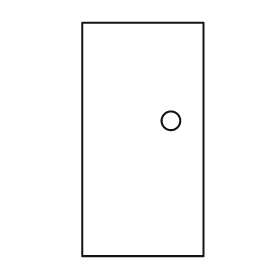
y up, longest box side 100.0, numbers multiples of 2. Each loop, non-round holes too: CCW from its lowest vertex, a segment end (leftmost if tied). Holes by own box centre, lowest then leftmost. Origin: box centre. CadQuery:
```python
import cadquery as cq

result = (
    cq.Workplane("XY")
    .moveTo(-26.0, -50.0)
    .lineTo(26.0, -50.0)
    .lineTo(26.0, 50.0)
    .lineTo(-26.0, 50.0)
    .close()
    .moveTo(12.0, 8.0)
    .circle(4.0)
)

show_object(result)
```